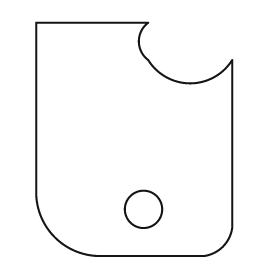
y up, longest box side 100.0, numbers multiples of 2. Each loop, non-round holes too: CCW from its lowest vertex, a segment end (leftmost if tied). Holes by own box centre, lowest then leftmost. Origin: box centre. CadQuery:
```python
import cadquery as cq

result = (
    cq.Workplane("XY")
    .moveTo(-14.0, -50.0)
    .lineTo(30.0, -50.0)
    .threePointArc((38.0, -46.0), (42.0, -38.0))
    .lineTo(42.0, 34.0)
    .threePointArc((24.0, 24.0), (6.0, 34.0))
    .threePointArc((2.0, 42.0), (6.0, 50.0))
    .lineTo(-42.0, 50.0)
    .lineTo(-42.0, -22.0)
    .threePointArc((-34.0, -42.0), (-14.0, -50.0))
    .close()
    .moveTo(4.0, -30.0)
    .circle(8.0)
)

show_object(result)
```